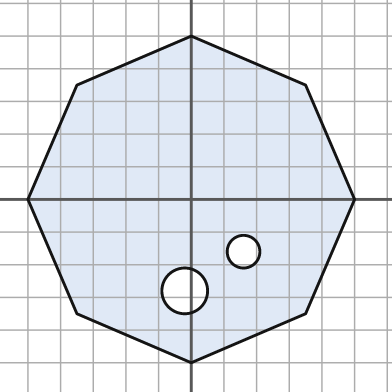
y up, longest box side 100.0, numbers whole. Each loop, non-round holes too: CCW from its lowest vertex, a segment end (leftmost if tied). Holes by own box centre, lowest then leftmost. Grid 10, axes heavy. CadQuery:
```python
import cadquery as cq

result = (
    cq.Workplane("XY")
    .moveTo(0.0, -50.0)
    .lineTo(35.0, -35.0)
    .lineTo(50.0, 0.0)
    .lineTo(35.0, 35.0)
    .lineTo(0.0, 50.0)
    .lineTo(-35.0, 35.0)
    .lineTo(-50.0, 0.0)
    .lineTo(-35.0, -35.0)
    .close()
    .moveTo(-2.0, -28.0)
    .circle(7.0)
    .moveTo(16.0, -16.0)
    .circle(5.0)
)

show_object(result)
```